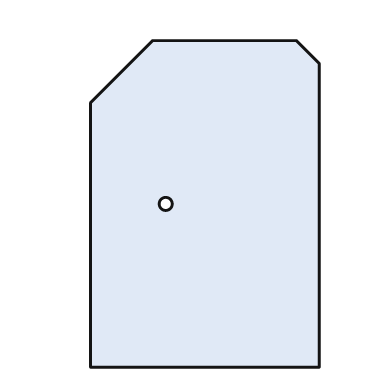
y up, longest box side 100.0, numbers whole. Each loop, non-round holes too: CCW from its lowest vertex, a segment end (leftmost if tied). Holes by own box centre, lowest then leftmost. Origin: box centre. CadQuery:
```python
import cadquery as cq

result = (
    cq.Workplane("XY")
    .moveTo(-35.0, -50.0)
    .lineTo(35.0, -50.0)
    .lineTo(35.0, 43.0)
    .lineTo(28.0, 50.0)
    .lineTo(-16.0, 50.0)
    .lineTo(-35.0, 31.0)
    .close()
    .moveTo(-12.0, 0.0)
    .circle(2.0)
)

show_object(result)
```